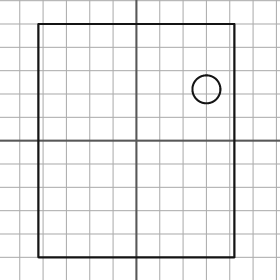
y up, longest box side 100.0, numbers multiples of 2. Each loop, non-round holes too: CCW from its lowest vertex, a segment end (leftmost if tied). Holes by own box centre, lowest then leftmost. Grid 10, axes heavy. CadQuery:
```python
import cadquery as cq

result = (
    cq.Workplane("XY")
    .moveTo(-42.0, -50.0)
    .lineTo(42.0, -50.0)
    .lineTo(42.0, 50.0)
    .lineTo(-42.0, 50.0)
    .close()
    .moveTo(30.0, 22.0)
    .circle(6.0)
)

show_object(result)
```